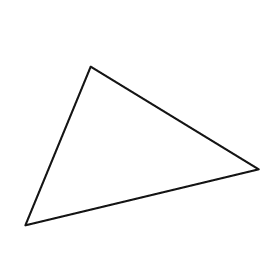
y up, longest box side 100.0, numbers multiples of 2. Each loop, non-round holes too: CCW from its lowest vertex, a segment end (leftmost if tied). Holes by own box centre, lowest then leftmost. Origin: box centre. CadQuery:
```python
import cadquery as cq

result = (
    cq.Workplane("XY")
    .moveTo(-50.0, -34.0)
    .lineTo(50.0, -10.0)
    .lineTo(-22.0, 34.0)
    .close()
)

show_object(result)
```